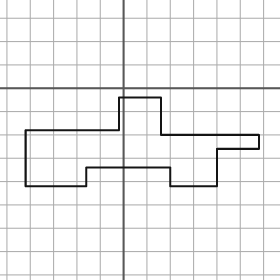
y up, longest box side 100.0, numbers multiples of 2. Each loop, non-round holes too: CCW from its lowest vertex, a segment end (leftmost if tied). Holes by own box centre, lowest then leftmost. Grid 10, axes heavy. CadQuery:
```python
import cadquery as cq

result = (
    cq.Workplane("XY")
    .moveTo(-42.0, -42.0)
    .lineTo(-16.0, -42.0)
    .lineTo(-16.0, -34.0)
    .lineTo(20.0, -34.0)
    .lineTo(20.0, -42.0)
    .lineTo(40.0, -42.0)
    .lineTo(40.0, -26.0)
    .lineTo(58.0, -26.0)
    .lineTo(58.0, -20.0)
    .lineTo(16.0, -20.0)
    .lineTo(16.0, -4.0)
    .lineTo(-2.0, -4.0)
    .lineTo(-2.0, -18.0)
    .lineTo(-42.0, -18.0)
    .close()
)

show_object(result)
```